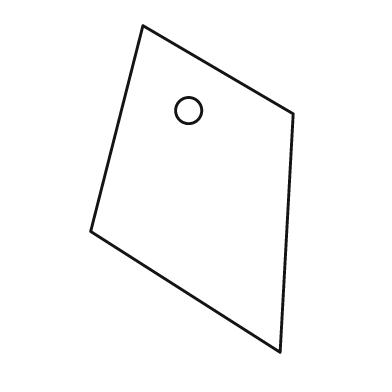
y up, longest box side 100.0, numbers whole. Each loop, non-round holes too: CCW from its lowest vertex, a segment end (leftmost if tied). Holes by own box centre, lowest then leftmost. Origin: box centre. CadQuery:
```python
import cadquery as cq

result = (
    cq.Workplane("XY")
    .moveTo(27.0, -50.0)
    .lineTo(31.0, 23.0)
    .lineTo(-15.0, 50.0)
    .lineTo(-31.0, -13.0)
    .close()
    .moveTo(-1.0, 24.0)
    .circle(4.0)
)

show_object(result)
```